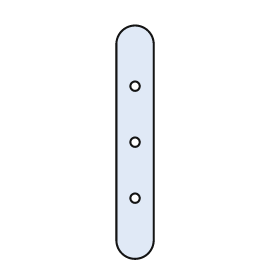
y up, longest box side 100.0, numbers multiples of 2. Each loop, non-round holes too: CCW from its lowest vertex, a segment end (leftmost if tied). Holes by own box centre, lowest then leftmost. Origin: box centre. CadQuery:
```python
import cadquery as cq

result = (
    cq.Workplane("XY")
    .moveTo(-8.0, -42.0)
    .threePointArc((0.0, -50.0), (8.0, -42.0))
    .lineTo(8.0, 42.0)
    .threePointArc((0.0, 50.0), (-8.0, 42.0))
    .close()
    .moveTo(0.0, -24.0)
    .circle(2.0)
    .moveTo(0.0, 0.0)
    .circle(2.0)
    .moveTo(0.0, 24.0)
    .circle(2.0)
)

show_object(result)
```